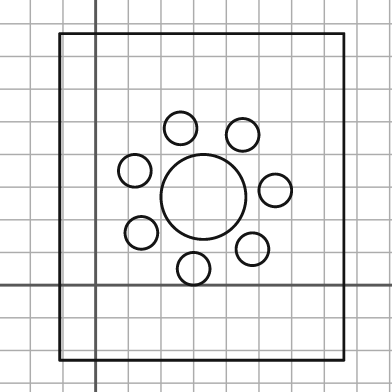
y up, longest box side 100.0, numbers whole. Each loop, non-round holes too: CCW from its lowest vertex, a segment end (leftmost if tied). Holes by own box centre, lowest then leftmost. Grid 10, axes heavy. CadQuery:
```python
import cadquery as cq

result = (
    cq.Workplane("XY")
    .moveTo(-11.0, -23.0)
    .lineTo(76.0, -23.0)
    .lineTo(76.0, 77.0)
    .lineTo(-11.0, 77.0)
    .close()
    .moveTo(30.0, 5.0)
    .circle(5.0)
    .moveTo(48.0, 11.0)
    .circle(5.0)
    .moveTo(14.0, 16.0)
    .circle(5.0)
    .moveTo(33.0, 27.0)
    .circle(13.0)
    .moveTo(55.0, 29.0)
    .circle(5.0)
    .moveTo(12.0, 35.0)
    .circle(5.0)
    .moveTo(45.0, 46.0)
    .circle(5.0)
    .moveTo(26.0, 48.0)
    .circle(5.0)
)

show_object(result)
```